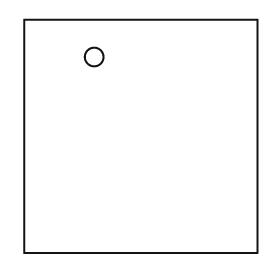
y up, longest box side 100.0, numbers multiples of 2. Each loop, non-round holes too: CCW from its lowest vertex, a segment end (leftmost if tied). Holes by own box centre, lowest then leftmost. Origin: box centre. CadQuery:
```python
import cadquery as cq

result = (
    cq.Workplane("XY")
    .moveTo(-50.0, -50.0)
    .lineTo(50.0, -50.0)
    .lineTo(50.0, 50.0)
    .lineTo(-50.0, 50.0)
    .close()
    .moveTo(-20.0, 34.0)
    .circle(4.0)
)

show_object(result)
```